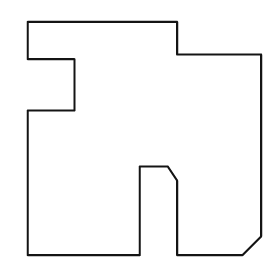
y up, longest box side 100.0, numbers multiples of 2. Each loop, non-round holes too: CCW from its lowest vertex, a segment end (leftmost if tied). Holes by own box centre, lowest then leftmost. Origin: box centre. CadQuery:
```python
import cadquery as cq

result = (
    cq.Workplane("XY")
    .moveTo(-50.0, -50.0)
    .lineTo(-2.0, -50.0)
    .lineTo(-2.0, -12.0)
    .lineTo(10.0, -12.0)
    .lineTo(14.0, -18.0)
    .lineTo(14.0, -50.0)
    .lineTo(42.0, -50.0)
    .lineTo(50.0, -42.0)
    .lineTo(50.0, 36.0)
    .lineTo(14.0, 36.0)
    .lineTo(14.0, 50.0)
    .lineTo(-50.0, 50.0)
    .lineTo(-50.0, 34.0)
    .lineTo(-30.0, 34.0)
    .lineTo(-30.0, 12.0)
    .lineTo(-50.0, 12.0)
    .close()
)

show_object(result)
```